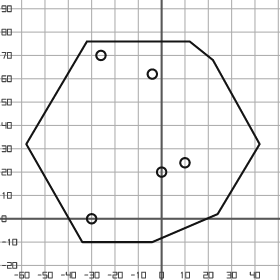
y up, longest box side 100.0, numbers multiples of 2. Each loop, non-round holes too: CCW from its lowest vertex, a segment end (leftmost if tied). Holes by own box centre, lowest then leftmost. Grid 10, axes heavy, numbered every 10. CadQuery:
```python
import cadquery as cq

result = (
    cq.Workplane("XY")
    .moveTo(-34.0, -10.0)
    .lineTo(-4.0, -10.0)
    .lineTo(24.0, 2.0)
    .lineTo(42.0, 32.0)
    .lineTo(22.0, 68.0)
    .lineTo(12.0, 76.0)
    .lineTo(-32.0, 76.0)
    .lineTo(-58.0, 32.0)
    .close()
    .moveTo(-30.0, 0.0)
    .circle(2.0)
    .moveTo(0.0, 20.0)
    .circle(2.0)
    .moveTo(10.0, 24.0)
    .circle(2.0)
    .moveTo(-4.0, 62.0)
    .circle(2.0)
    .moveTo(-26.0, 70.0)
    .circle(2.0)
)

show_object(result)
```